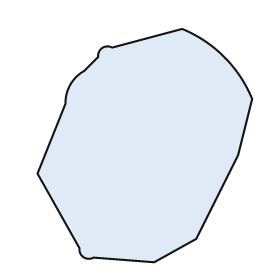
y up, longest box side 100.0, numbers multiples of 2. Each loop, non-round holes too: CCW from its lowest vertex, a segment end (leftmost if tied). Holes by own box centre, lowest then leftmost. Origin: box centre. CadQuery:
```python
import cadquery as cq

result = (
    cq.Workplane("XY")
    .moveTo(4.0, -50.0)
    .lineTo(22.0, -40.0)
    .lineTo(40.0, -4.0)
    .lineTo(46.0, 20.0)
    .threePointArc((34.0, 38.0), (16.0, 50.0))
    .lineTo(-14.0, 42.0)
    .threePointArc((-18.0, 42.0), (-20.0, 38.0))
    .lineTo(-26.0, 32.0)
    .threePointArc((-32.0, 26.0), (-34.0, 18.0))
    .lineTo(-46.0, -12.0)
    .lineTo(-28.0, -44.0)
    .threePointArc((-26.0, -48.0), (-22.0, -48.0))
    .close()
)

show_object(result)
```